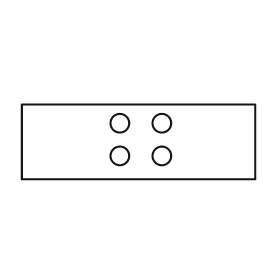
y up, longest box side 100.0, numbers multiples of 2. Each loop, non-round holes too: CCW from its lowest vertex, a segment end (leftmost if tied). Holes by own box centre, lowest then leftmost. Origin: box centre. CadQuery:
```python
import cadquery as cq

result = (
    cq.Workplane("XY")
    .moveTo(-50.0, -16.0)
    .lineTo(50.0, -16.0)
    .lineTo(50.0, 16.0)
    .lineTo(-50.0, 16.0)
    .close()
    .moveTo(-8.0, -6.0)
    .circle(4.0)
    .moveTo(10.0, -6.0)
    .circle(4.0)
    .moveTo(-8.0, 8.0)
    .circle(4.0)
    .moveTo(10.0, 8.0)
    .circle(4.0)
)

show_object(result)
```